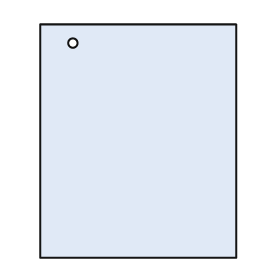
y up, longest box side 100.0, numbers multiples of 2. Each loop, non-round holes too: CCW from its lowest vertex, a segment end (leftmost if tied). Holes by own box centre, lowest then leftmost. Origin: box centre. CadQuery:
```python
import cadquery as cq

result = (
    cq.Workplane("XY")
    .moveTo(-42.0, -50.0)
    .lineTo(42.0, -50.0)
    .lineTo(42.0, 50.0)
    .lineTo(-42.0, 50.0)
    .close()
    .moveTo(-28.0, 42.0)
    .circle(2.0)
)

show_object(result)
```